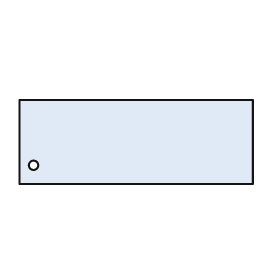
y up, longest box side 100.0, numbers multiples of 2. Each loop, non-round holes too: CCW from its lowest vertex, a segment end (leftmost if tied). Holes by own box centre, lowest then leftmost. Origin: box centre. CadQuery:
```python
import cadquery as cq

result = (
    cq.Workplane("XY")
    .moveTo(-50.0, -18.0)
    .lineTo(50.0, -18.0)
    .lineTo(50.0, 18.0)
    .lineTo(-50.0, 18.0)
    .close()
    .moveTo(-44.0, -10.0)
    .circle(2.0)
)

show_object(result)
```